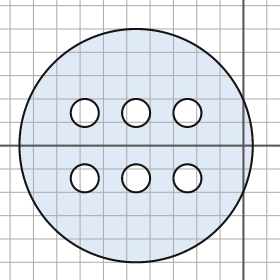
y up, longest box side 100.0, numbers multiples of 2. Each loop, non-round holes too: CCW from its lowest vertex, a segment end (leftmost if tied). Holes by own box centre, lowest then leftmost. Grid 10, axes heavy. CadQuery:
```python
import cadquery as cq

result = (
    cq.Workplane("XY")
    .moveTo(-46.0, 0.0)
    .circle(50.0)
    .moveTo(-68.0, -14.0)
    .circle(6.0)
    .moveTo(-46.0, -14.0)
    .circle(6.0)
    .moveTo(-24.0, -14.0)
    .circle(6.0)
    .moveTo(-68.0, 14.0)
    .circle(6.0)
    .moveTo(-46.0, 14.0)
    .circle(6.0)
    .moveTo(-24.0, 14.0)
    .circle(6.0)
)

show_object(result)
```